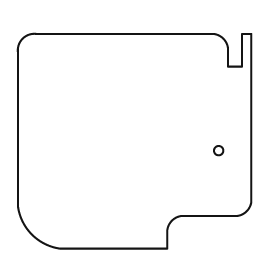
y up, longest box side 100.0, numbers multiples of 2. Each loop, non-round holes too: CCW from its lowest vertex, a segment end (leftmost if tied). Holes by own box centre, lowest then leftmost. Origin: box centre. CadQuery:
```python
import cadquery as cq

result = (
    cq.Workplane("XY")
    .moveTo(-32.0, -46.0)
    .lineTo(14.0, -46.0)
    .lineTo(14.0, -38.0)
    .threePointArc((16.0, -34.0), (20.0, -32.0))
    .lineTo(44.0, -32.0)
    .threePointArc((48.0, -30.0), (50.0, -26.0))
    .lineTo(50.0, 46.0)
    .lineTo(46.0, 46.0)
    .lineTo(46.0, 32.0)
    .lineTo(40.0, 32.0)
    .lineTo(40.0, 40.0)
    .threePointArc((38.0, 44.0), (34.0, 46.0))
    .lineTo(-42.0, 46.0)
    .threePointArc((-48.0, 44.0), (-50.0, 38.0))
    .lineTo(-50.0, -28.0)
    .threePointArc((-44.0, -40.0), (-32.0, -46.0))
    .close()
    .moveTo(36.0, -4.0)
    .circle(2.0)
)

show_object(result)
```